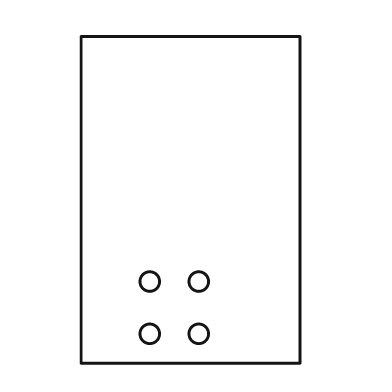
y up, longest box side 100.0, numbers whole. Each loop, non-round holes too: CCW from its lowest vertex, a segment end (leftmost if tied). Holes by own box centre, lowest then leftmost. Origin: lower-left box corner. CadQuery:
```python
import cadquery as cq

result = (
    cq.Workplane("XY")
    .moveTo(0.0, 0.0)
    .lineTo(67.0, 0.0)
    .lineTo(67.0, 100.0)
    .lineTo(0.0, 100.0)
    .close()
    .moveTo(21.0, 9.0)
    .circle(3.0)
    .moveTo(36.0, 9.0)
    .circle(3.0)
    .moveTo(21.0, 25.0)
    .circle(3.0)
    .moveTo(36.0, 25.0)
    .circle(3.0)
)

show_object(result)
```